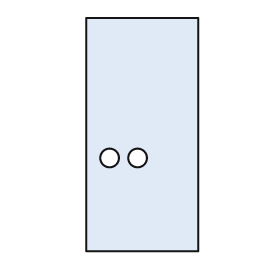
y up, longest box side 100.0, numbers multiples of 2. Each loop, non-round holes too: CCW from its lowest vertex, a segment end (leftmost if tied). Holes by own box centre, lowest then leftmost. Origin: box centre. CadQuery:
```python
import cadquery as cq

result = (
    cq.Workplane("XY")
    .moveTo(-24.0, -50.0)
    .lineTo(24.0, -50.0)
    .lineTo(24.0, 50.0)
    .lineTo(-24.0, 50.0)
    .close()
    .moveTo(-14.0, -10.0)
    .circle(4.0)
    .moveTo(-2.0, -10.0)
    .circle(4.0)
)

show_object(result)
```